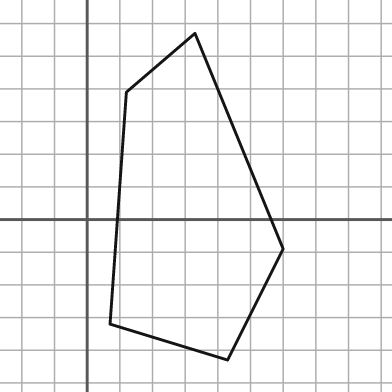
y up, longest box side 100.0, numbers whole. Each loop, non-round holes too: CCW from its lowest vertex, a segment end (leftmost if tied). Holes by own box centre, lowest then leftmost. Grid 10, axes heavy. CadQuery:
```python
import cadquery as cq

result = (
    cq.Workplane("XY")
    .moveTo(43.0, -43.0)
    .lineTo(60.0, -9.0)
    .lineTo(33.0, 57.0)
    .lineTo(12.0, 39.0)
    .lineTo(7.0, -32.0)
    .close()
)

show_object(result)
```